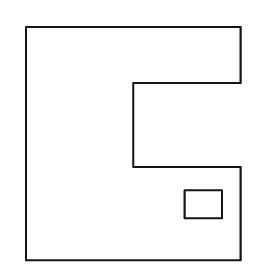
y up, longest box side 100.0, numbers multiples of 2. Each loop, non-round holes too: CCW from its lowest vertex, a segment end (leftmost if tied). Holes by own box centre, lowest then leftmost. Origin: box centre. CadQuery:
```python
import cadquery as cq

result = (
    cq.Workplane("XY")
    .moveTo(-46.0, -50.0)
    .lineTo(46.0, -50.0)
    .lineTo(46.0, -10.0)
    .lineTo(0.0, -10.0)
    .lineTo(0.0, 26.0)
    .lineTo(46.0, 26.0)
    .lineTo(46.0, 50.0)
    .lineTo(-46.0, 50.0)
    .close()
    .moveTo(22.0, -32.0)
    .lineTo(38.0, -32.0)
    .lineTo(38.0, -20.0)
    .lineTo(22.0, -20.0)
    .close()
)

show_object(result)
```